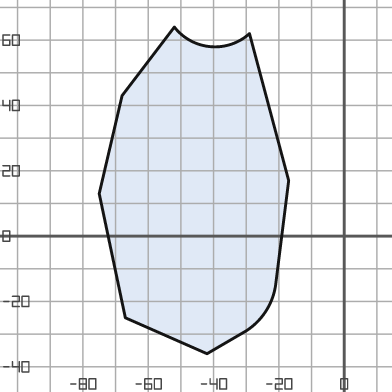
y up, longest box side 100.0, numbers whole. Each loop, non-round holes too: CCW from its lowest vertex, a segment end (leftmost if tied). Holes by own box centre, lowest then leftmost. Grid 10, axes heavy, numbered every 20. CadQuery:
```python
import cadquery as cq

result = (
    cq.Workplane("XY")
    .moveTo(-42.0, -36.0)
    .lineTo(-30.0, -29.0)
    .threePointArc((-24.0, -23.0), (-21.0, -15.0))
    .lineTo(-17.0, 17.0)
    .lineTo(-29.0, 62.0)
    .threePointArc((-41.0, 58.0), (-52.0, 64.0))
    .lineTo(-68.0, 43.0)
    .lineTo(-75.0, 13.0)
    .lineTo(-67.0, -25.0)
    .close()
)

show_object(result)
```